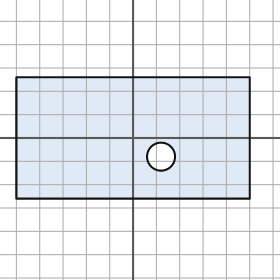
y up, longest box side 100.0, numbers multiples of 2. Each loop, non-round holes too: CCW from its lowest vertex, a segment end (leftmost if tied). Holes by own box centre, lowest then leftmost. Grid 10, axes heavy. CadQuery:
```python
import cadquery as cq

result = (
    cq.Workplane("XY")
    .moveTo(-50.0, -26.0)
    .lineTo(50.0, -26.0)
    .lineTo(50.0, 26.0)
    .lineTo(-50.0, 26.0)
    .close()
    .moveTo(12.0, -8.0)
    .circle(6.0)
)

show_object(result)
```